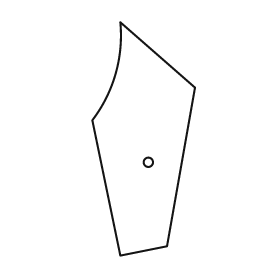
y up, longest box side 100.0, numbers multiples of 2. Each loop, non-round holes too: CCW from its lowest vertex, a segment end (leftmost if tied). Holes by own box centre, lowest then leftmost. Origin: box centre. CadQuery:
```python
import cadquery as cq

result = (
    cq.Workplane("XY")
    .moveTo(-10.0, -50.0)
    .lineTo(10.0, -46.0)
    .lineTo(22.0, 22.0)
    .lineTo(-10.0, 50.0)
    .threePointArc((-12.0, 28.0), (-22.0, 8.0))
    .close()
    .moveTo(2.0, -10.0)
    .circle(2.0)
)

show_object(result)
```